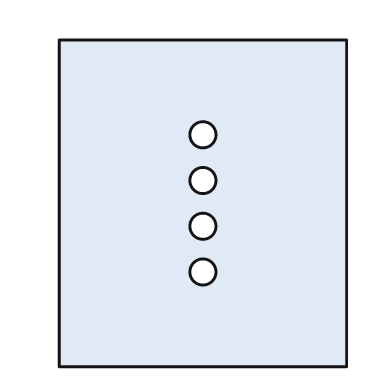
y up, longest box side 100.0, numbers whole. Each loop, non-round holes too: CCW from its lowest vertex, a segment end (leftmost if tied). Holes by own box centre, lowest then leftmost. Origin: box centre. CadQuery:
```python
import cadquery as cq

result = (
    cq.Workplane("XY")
    .moveTo(-44.0, -50.0)
    .lineTo(44.0, -50.0)
    .lineTo(44.0, 50.0)
    .lineTo(-44.0, 50.0)
    .close()
    .moveTo(0.0, -21.0)
    .circle(4.0)
    .moveTo(0.0, -7.0)
    .circle(4.0)
    .moveTo(0.0, 7.0)
    .circle(4.0)
    .moveTo(0.0, 21.0)
    .circle(4.0)
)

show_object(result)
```